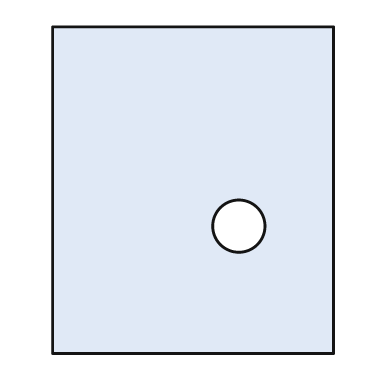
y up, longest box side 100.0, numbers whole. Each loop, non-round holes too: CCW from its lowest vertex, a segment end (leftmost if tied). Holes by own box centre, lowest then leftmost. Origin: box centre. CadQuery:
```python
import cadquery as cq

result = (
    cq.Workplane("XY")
    .moveTo(-43.0, -50.0)
    .lineTo(43.0, -50.0)
    .lineTo(43.0, 50.0)
    .lineTo(-43.0, 50.0)
    .close()
    .moveTo(14.0, -11.0)
    .circle(8.0)
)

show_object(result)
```